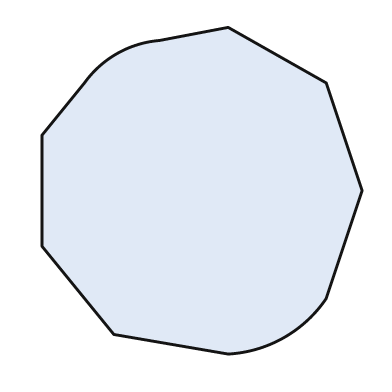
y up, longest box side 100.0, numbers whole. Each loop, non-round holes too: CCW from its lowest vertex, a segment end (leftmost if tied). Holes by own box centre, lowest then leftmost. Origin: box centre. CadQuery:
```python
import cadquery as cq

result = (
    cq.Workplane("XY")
    .moveTo(8.0, -50.0)
    .threePointArc((25.0, -45.0), (38.0, -33.0))
    .lineTo(49.0, 0.0)
    .lineTo(38.0, 33.0)
    .lineTo(8.0, 50.0)
    .lineTo(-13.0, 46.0)
    .threePointArc((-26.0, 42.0), (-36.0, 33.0))
    .lineTo(-49.0, 17.0)
    .lineTo(-49.0, -17.0)
    .lineTo(-27.0, -44.0)
    .close()
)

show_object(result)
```